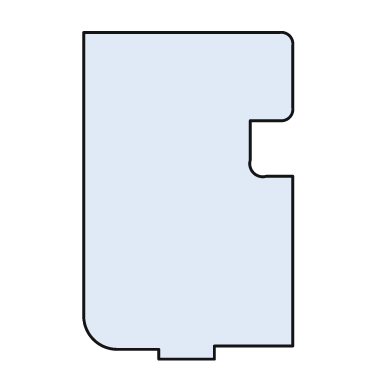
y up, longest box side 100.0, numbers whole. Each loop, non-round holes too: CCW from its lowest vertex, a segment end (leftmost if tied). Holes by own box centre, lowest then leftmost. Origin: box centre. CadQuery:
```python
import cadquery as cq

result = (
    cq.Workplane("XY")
    .moveTo(-9.0, -50.0)
    .lineTo(8.0, -50.0)
    .lineTo(8.0, -46.0)
    .lineTo(32.0, -46.0)
    .lineTo(32.0, 6.0)
    .lineTo(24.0, 6.0)
    .threePointArc((20.0, 7.0), (19.0, 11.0))
    .lineTo(19.0, 23.0)
    .lineTo(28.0, 23.0)
    .threePointArc((31.0, 24.0), (32.0, 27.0))
    .lineTo(32.0, 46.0)
    .threePointArc((31.0, 49.0), (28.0, 50.0))
    .lineTo(-32.0, 50.0)
    .lineTo(-32.0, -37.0)
    .threePointArc((-29.0, -44.0), (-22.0, -47.0))
    .lineTo(-9.0, -47.0)
    .close()
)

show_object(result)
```